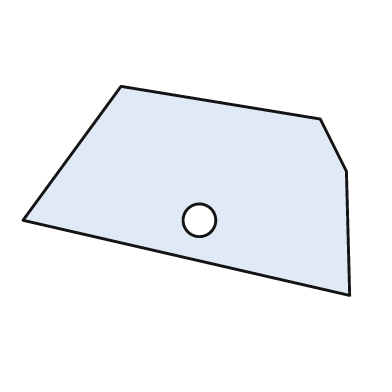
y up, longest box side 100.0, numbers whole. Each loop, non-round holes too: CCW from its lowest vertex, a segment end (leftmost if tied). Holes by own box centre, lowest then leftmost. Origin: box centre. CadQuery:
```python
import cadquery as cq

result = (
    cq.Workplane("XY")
    .moveTo(50.0, -32.0)
    .lineTo(49.0, 6.0)
    .lineTo(41.0, 22.0)
    .lineTo(-20.0, 32.0)
    .lineTo(-50.0, -9.0)
    .close()
    .moveTo(4.0, -9.0)
    .circle(5.0)
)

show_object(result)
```